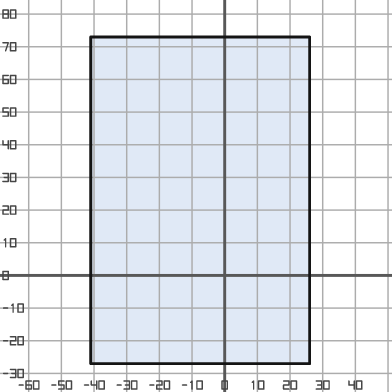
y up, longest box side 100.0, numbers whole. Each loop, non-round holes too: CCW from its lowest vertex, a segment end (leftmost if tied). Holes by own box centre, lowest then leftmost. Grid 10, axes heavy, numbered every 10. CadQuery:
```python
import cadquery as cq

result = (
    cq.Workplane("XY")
    .moveTo(-41.0, -27.0)
    .lineTo(26.0, -27.0)
    .lineTo(26.0, 73.0)
    .lineTo(-41.0, 73.0)
    .close()
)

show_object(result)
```